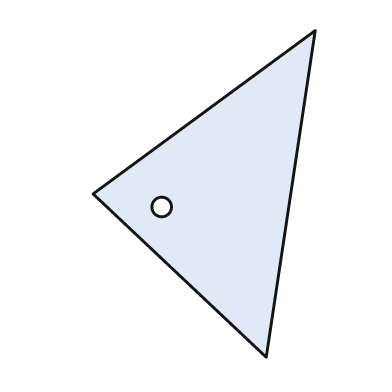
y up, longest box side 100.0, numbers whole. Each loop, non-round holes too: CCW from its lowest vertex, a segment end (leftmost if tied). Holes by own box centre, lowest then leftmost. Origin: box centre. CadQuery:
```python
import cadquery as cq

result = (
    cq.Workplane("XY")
    .moveTo(19.0, -50.0)
    .lineTo(34.0, 50.0)
    .lineTo(-34.0, 0.0)
    .close()
    .moveTo(-13.0, -4.0)
    .circle(3.0)
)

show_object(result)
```